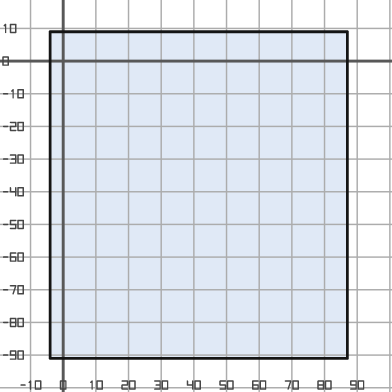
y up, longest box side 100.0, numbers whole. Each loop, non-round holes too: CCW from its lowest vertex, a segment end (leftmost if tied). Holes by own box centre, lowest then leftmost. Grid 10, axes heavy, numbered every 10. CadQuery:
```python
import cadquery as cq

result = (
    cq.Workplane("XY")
    .moveTo(-4.0, -91.0)
    .lineTo(87.0, -91.0)
    .lineTo(87.0, 9.0)
    .lineTo(-4.0, 9.0)
    .close()
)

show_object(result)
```